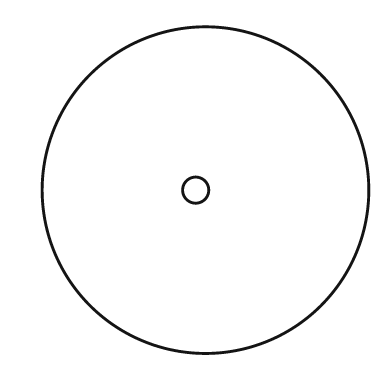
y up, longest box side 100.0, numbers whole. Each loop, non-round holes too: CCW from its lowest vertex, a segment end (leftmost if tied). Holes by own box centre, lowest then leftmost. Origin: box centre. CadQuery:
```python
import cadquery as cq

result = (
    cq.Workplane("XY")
    .moveTo(0.0, 0.0)
    .circle(50.0)
    .moveTo(-3.0, 0.0)
    .circle(4.0)
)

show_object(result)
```